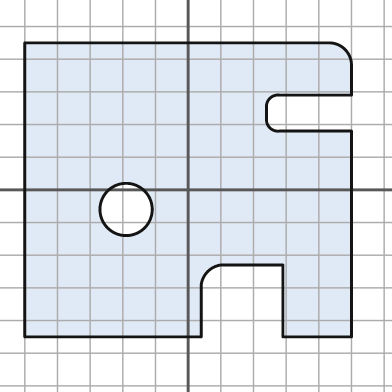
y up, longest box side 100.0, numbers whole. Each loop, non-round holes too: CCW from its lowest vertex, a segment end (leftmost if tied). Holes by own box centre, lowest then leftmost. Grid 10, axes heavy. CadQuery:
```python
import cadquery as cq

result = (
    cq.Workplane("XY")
    .moveTo(-50.0, -45.0)
    .lineTo(4.0, -45.0)
    .lineTo(4.0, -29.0)
    .threePointArc((6.0, -25.0), (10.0, -23.0))
    .lineTo(29.0, -23.0)
    .lineTo(29.0, -45.0)
    .lineTo(50.0, -45.0)
    .lineTo(50.0, 18.0)
    .lineTo(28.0, 18.0)
    .threePointArc((25.0, 19.0), (24.0, 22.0))
    .lineTo(24.0, 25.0)
    .threePointArc((25.0, 28.0), (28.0, 29.0))
    .lineTo(50.0, 29.0)
    .lineTo(50.0, 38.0)
    .threePointArc((48.0, 43.0), (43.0, 45.0))
    .lineTo(-50.0, 45.0)
    .close()
    .moveTo(-19.0, -6.0)
    .circle(8.0)
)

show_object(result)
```